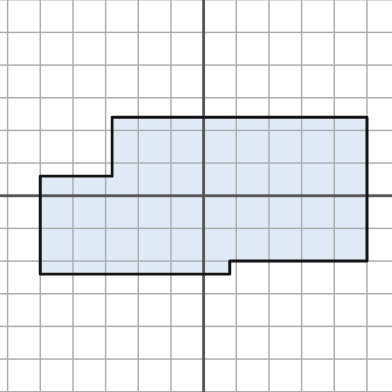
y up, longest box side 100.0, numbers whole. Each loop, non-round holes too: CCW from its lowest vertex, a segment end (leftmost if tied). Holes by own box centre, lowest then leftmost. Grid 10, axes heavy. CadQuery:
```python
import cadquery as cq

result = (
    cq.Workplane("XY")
    .moveTo(-50.0, -24.0)
    .lineTo(8.0, -24.0)
    .lineTo(8.0, -20.0)
    .lineTo(50.0, -20.0)
    .lineTo(50.0, 24.0)
    .lineTo(-28.0, 24.0)
    .lineTo(-28.0, 6.0)
    .lineTo(-50.0, 6.0)
    .close()
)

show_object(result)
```